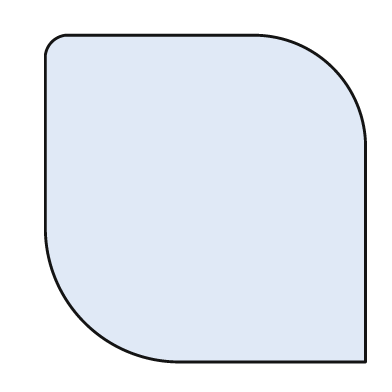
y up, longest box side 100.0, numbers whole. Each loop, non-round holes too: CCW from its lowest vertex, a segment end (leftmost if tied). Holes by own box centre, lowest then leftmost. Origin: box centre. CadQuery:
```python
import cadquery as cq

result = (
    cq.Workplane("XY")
    .moveTo(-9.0, -50.0)
    .lineTo(49.0, -50.0)
    .lineTo(49.0, 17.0)
    .threePointArc((39.0, 40.0), (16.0, 50.0))
    .lineTo(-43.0, 50.0)
    .threePointArc((-47.0, 48.0), (-49.0, 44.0))
    .lineTo(-49.0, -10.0)
    .threePointArc((-37.0, -38.0), (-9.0, -50.0))
    .close()
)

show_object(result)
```